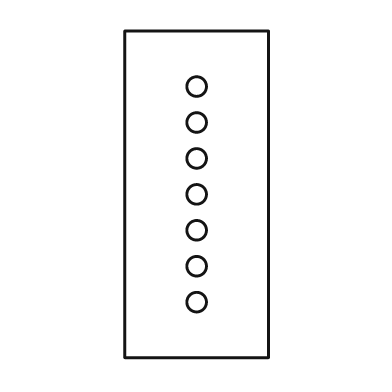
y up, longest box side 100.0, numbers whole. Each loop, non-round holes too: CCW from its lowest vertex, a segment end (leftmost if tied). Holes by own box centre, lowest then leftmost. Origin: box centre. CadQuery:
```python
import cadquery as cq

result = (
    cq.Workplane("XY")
    .moveTo(-22.0, -50.0)
    .lineTo(22.0, -50.0)
    .lineTo(22.0, 50.0)
    .lineTo(-22.0, 50.0)
    .close()
    .moveTo(0.0, -33.0)
    .circle(3.0)
    .moveTo(0.0, -22.0)
    .circle(3.0)
    .moveTo(0.0, -11.0)
    .circle(3.0)
    .moveTo(0.0, 0.0)
    .circle(3.0)
    .moveTo(0.0, 11.0)
    .circle(3.0)
    .moveTo(0.0, 22.0)
    .circle(3.0)
    .moveTo(0.0, 33.0)
    .circle(3.0)
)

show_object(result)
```